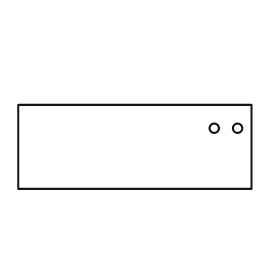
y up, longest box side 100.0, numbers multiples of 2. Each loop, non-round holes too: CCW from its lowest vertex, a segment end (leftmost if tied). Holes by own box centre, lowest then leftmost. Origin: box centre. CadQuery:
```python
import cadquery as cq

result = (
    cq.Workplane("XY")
    .moveTo(-50.0, -18.0)
    .lineTo(50.0, -18.0)
    .lineTo(50.0, 18.0)
    .lineTo(-50.0, 18.0)
    .close()
    .moveTo(34.0, 8.0)
    .circle(2.0)
    .moveTo(44.0, 8.0)
    .circle(2.0)
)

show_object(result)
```